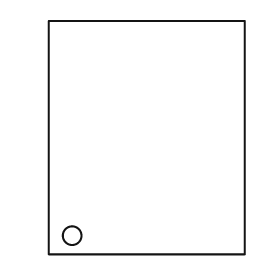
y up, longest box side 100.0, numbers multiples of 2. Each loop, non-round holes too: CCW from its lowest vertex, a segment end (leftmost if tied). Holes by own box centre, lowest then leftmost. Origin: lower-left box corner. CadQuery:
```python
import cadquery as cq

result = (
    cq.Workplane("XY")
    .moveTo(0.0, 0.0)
    .lineTo(84.0, 0.0)
    .lineTo(84.0, 100.0)
    .lineTo(0.0, 100.0)
    .close()
    .moveTo(10.0, 8.0)
    .circle(4.0)
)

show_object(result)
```